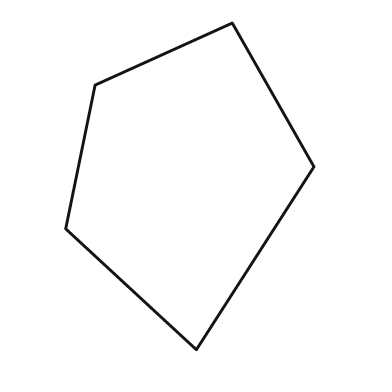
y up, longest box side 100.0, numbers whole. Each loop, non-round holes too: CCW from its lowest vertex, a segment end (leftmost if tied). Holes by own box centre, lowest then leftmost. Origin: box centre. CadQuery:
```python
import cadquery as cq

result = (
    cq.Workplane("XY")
    .moveTo(2.0, -50.0)
    .lineTo(38.0, 6.0)
    .lineTo(13.0, 50.0)
    .lineTo(-29.0, 31.0)
    .lineTo(-38.0, -13.0)
    .close()
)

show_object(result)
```